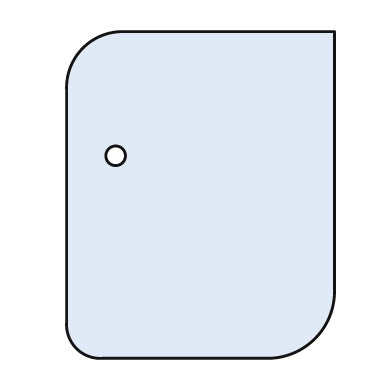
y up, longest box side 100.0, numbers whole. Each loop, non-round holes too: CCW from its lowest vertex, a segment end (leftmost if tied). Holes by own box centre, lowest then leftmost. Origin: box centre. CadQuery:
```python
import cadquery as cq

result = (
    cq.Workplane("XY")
    .moveTo(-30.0, -50.0)
    .lineTo(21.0, -50.0)
    .threePointArc((35.0, -44.0), (41.0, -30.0))
    .lineTo(41.0, 50.0)
    .lineTo(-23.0, 50.0)
    .threePointArc((-36.0, 45.0), (-41.0, 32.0))
    .lineTo(-41.0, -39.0)
    .threePointArc((-38.0, -47.0), (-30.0, -50.0))
    .close()
    .moveTo(-26.0, 12.0)
    .circle(3.0)
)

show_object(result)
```